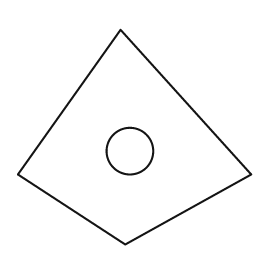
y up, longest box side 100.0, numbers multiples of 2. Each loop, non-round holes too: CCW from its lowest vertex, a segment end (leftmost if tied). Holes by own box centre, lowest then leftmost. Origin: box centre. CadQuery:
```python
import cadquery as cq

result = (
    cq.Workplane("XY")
    .moveTo(-4.0, -46.0)
    .lineTo(50.0, -16.0)
    .lineTo(-6.0, 46.0)
    .lineTo(-50.0, -16.0)
    .close()
    .moveTo(-2.0, -6.0)
    .circle(10.0)
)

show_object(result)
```